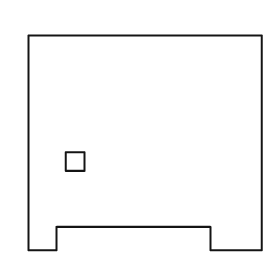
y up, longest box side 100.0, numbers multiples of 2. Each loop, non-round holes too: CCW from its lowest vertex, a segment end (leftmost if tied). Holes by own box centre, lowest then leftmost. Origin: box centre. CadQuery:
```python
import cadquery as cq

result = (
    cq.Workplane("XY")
    .moveTo(-50.0, -46.0)
    .lineTo(-38.0, -46.0)
    .lineTo(-38.0, -36.0)
    .lineTo(28.0, -36.0)
    .lineTo(28.0, -46.0)
    .lineTo(50.0, -46.0)
    .lineTo(50.0, 46.0)
    .lineTo(-50.0, 46.0)
    .close()
    .moveTo(-34.0, -12.0)
    .lineTo(-26.0, -12.0)
    .lineTo(-26.0, -4.0)
    .lineTo(-34.0, -4.0)
    .close()
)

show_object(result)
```